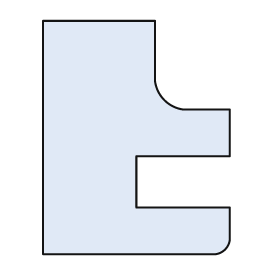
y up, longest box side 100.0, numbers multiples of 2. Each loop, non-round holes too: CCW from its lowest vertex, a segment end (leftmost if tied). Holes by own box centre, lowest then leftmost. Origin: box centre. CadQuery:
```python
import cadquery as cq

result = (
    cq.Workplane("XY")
    .moveTo(-40.0, -50.0)
    .lineTo(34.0, -50.0)
    .threePointArc((38.0, -48.0), (40.0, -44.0))
    .lineTo(40.0, -30.0)
    .lineTo(0.0, -30.0)
    .lineTo(0.0, -8.0)
    .lineTo(40.0, -8.0)
    .lineTo(40.0, 12.0)
    .lineTo(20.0, 12.0)
    .threePointArc((12.0, 16.0), (8.0, 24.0))
    .lineTo(8.0, 50.0)
    .lineTo(-40.0, 50.0)
    .close()
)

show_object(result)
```